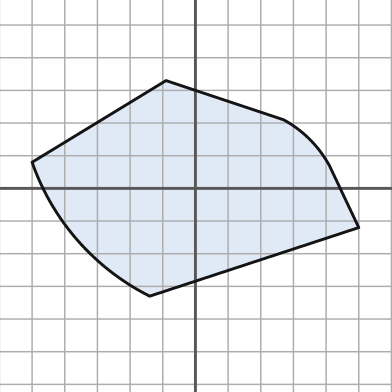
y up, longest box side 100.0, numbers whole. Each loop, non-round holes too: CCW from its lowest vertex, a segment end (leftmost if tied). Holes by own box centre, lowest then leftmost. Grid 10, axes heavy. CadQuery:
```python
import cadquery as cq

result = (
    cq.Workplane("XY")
    .moveTo(-14.0, -33.0)
    .lineTo(50.0, -12.0)
    .lineTo(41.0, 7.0)
    .threePointArc((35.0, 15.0), (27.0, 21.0))
    .lineTo(-9.0, 33.0)
    .lineTo(-50.0, 8.0)
    .threePointArc((-36.0, -16.0), (-14.0, -33.0))
    .close()
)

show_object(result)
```